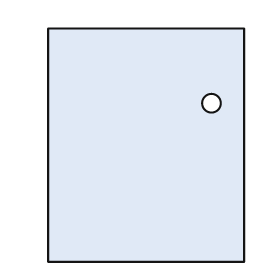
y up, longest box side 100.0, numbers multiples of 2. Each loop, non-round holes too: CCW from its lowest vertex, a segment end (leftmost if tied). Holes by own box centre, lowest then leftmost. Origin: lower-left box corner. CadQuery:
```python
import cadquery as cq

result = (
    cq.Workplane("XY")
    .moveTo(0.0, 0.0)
    .lineTo(84.0, 0.0)
    .lineTo(84.0, 100.0)
    .lineTo(0.0, 100.0)
    .close()
    .moveTo(70.0, 68.0)
    .circle(4.0)
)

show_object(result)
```